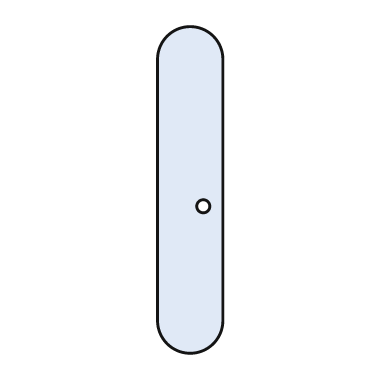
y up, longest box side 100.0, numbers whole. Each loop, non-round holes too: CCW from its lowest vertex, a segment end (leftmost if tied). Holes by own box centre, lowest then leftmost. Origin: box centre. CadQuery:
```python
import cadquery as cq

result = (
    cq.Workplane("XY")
    .moveTo(-10.0, -40.0)
    .threePointArc((0.0, -50.0), (10.0, -40.0))
    .lineTo(10.0, 40.0)
    .threePointArc((0.0, 50.0), (-10.0, 40.0))
    .close()
    .moveTo(4.0, -5.0)
    .circle(2.0)
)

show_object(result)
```